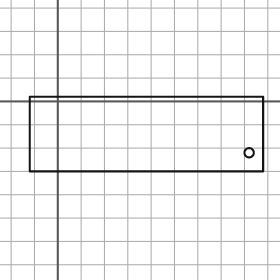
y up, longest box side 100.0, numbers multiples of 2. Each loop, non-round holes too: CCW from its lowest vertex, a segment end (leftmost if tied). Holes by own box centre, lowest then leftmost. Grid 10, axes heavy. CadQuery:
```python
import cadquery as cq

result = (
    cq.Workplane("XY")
    .moveTo(-12.0, -30.0)
    .lineTo(88.0, -30.0)
    .lineTo(88.0, 2.0)
    .lineTo(-12.0, 2.0)
    .close()
    .moveTo(82.0, -22.0)
    .circle(2.0)
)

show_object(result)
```